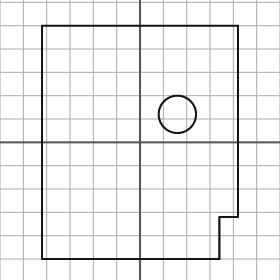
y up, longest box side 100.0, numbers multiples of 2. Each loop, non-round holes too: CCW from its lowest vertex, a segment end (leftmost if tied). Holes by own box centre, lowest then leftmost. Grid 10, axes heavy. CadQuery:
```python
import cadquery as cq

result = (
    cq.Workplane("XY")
    .moveTo(-42.0, -50.0)
    .lineTo(34.0, -50.0)
    .lineTo(34.0, -32.0)
    .lineTo(42.0, -32.0)
    .lineTo(42.0, 50.0)
    .lineTo(-42.0, 50.0)
    .close()
    .moveTo(16.0, 12.0)
    .circle(8.0)
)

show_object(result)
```